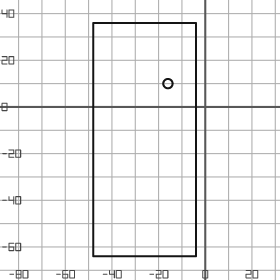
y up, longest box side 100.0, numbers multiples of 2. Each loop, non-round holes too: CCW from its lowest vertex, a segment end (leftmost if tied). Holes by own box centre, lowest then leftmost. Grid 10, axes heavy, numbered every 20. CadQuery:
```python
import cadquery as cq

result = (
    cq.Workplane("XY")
    .moveTo(-48.0, -64.0)
    .lineTo(-4.0, -64.0)
    .lineTo(-4.0, 36.0)
    .lineTo(-48.0, 36.0)
    .close()
    .moveTo(-16.0, 10.0)
    .circle(2.0)
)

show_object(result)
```